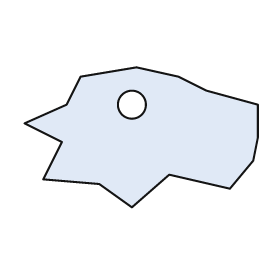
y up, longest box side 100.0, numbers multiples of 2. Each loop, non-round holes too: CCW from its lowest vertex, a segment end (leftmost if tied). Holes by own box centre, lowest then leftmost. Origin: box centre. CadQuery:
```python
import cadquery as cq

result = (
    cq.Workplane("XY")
    .moveTo(-4.0, -30.0)
    .lineTo(12.0, -16.0)
    .lineTo(38.0, -22.0)
    .lineTo(48.0, -10.0)
    .lineTo(50.0, 0.0)
    .lineTo(50.0, 14.0)
    .lineTo(28.0, 20.0)
    .lineTo(16.0, 26.0)
    .lineTo(-2.0, 30.0)
    .lineTo(-26.0, 26.0)
    .lineTo(-32.0, 14.0)
    .lineTo(-50.0, 6.0)
    .lineTo(-34.0, -2.0)
    .lineTo(-42.0, -18.0)
    .lineTo(-18.0, -20.0)
    .close()
    .moveTo(-4.0, 14.0)
    .circle(6.0)
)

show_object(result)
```